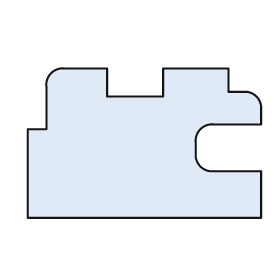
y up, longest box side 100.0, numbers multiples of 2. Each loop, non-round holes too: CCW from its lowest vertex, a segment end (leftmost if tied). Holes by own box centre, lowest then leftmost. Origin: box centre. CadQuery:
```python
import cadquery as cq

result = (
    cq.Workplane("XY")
    .moveTo(-50.0, -32.0)
    .lineTo(50.0, -32.0)
    .lineTo(50.0, -12.0)
    .lineTo(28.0, -12.0)
    .threePointArc((24.0, -10.0), (22.0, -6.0))
    .lineTo(22.0, 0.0)
    .threePointArc((24.0, 6.0), (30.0, 8.0))
    .lineTo(50.0, 8.0)
    .lineTo(50.0, 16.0)
    .threePointArc((48.0, 20.0), (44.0, 22.0))
    .lineTo(36.0, 22.0)
    .lineTo(36.0, 32.0)
    .lineTo(8.0, 32.0)
    .lineTo(8.0, 20.0)
    .lineTo(-16.0, 20.0)
    .lineTo(-16.0, 32.0)
    .lineTo(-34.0, 32.0)
    .threePointArc((-40.0, 30.0), (-42.0, 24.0))
    .lineTo(-42.0, 6.0)
    .lineTo(-50.0, 6.0)
    .close()
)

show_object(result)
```